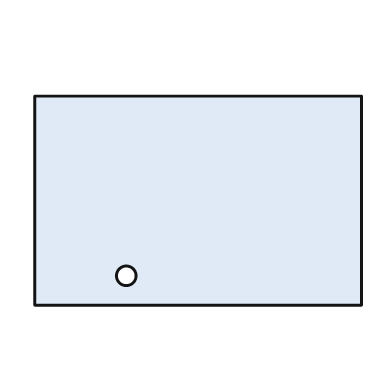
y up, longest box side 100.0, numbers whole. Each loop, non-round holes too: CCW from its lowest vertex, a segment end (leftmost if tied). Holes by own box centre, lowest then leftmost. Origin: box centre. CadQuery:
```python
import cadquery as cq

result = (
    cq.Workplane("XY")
    .moveTo(-50.0, -32.0)
    .lineTo(50.0, -32.0)
    .lineTo(50.0, 32.0)
    .lineTo(-50.0, 32.0)
    .close()
    .moveTo(-22.0, -23.0)
    .circle(3.0)
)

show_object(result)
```